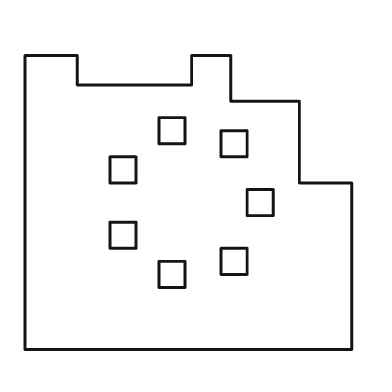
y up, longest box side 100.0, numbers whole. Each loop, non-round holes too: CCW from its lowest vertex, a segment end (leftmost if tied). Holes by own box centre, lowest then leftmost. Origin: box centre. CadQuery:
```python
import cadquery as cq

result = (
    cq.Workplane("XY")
    .moveTo(-50.0, -45.0)
    .lineTo(50.0, -45.0)
    .lineTo(50.0, 6.0)
    .lineTo(34.0, 6.0)
    .lineTo(34.0, 31.0)
    .lineTo(13.0, 31.0)
    .lineTo(13.0, 45.0)
    .lineTo(1.0, 45.0)
    .lineTo(1.0, 36.0)
    .lineTo(-34.0, 36.0)
    .lineTo(-34.0, 45.0)
    .lineTo(-50.0, 45.0)
    .close()
    .moveTo(-9.0, -26.0)
    .lineTo(-1.0, -26.0)
    .lineTo(-1.0, -18.0)
    .lineTo(-9.0, -18.0)
    .close()
    .moveTo(10.0, -22.0)
    .lineTo(18.0, -22.0)
    .lineTo(18.0, -14.0)
    .lineTo(10.0, -14.0)
    .close()
    .moveTo(-24.0, -14.0)
    .lineTo(-16.0, -14.0)
    .lineTo(-16.0, -6.0)
    .lineTo(-24.0, -6.0)
    .close()
    .moveTo(18.0, -4.0)
    .lineTo(26.0, -4.0)
    .lineTo(26.0, 4.0)
    .lineTo(18.0, 4.0)
    .close()
    .moveTo(-24.0, 6.0)
    .lineTo(-16.0, 6.0)
    .lineTo(-16.0, 14.0)
    .lineTo(-24.0, 14.0)
    .close()
    .moveTo(10.0, 14.0)
    .lineTo(18.0, 14.0)
    .lineTo(18.0, 22.0)
    .lineTo(10.0, 22.0)
    .close()
    .moveTo(-9.0, 18.0)
    .lineTo(-1.0, 18.0)
    .lineTo(-1.0, 26.0)
    .lineTo(-9.0, 26.0)
    .close()
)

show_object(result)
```